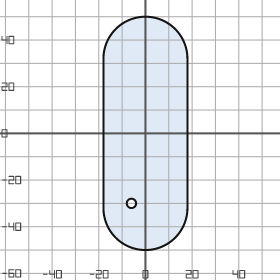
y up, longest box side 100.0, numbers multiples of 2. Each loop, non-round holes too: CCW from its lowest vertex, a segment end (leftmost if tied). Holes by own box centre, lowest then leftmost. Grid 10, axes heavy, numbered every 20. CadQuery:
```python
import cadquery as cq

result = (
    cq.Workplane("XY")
    .moveTo(-18.0, -32.0)
    .threePointArc((0.0, -50.0), (18.0, -32.0))
    .lineTo(18.0, 32.0)
    .threePointArc((0.0, 50.0), (-18.0, 32.0))
    .close()
    .moveTo(-6.0, -30.0)
    .circle(2.0)
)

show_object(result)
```